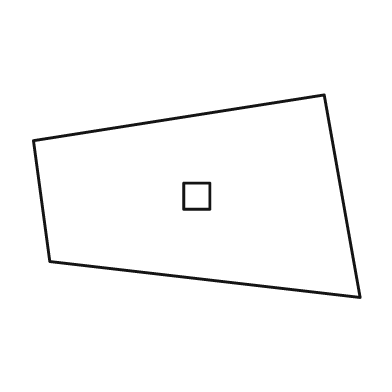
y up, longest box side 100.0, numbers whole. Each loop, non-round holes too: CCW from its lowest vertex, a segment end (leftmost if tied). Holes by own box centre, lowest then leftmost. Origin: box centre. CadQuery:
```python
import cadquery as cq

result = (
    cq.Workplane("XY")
    .moveTo(50.0, -31.0)
    .lineTo(39.0, 31.0)
    .lineTo(-50.0, 17.0)
    .lineTo(-45.0, -20.0)
    .close()
    .moveTo(-4.0, -4.0)
    .lineTo(4.0, -4.0)
    .lineTo(4.0, 4.0)
    .lineTo(-4.0, 4.0)
    .close()
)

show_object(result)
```